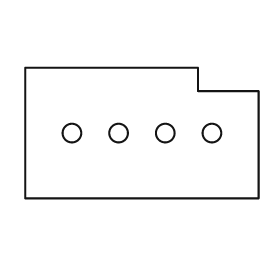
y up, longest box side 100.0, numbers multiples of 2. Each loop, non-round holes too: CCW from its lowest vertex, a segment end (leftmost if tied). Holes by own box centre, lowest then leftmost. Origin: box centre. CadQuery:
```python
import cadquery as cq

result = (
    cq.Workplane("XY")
    .moveTo(-50.0, -28.0)
    .lineTo(50.0, -28.0)
    .lineTo(50.0, 18.0)
    .lineTo(24.0, 18.0)
    .lineTo(24.0, 28.0)
    .lineTo(-50.0, 28.0)
    .close()
    .moveTo(-30.0, 0.0)
    .circle(4.0)
    .moveTo(-10.0, 0.0)
    .circle(4.0)
    .moveTo(10.0, 0.0)
    .circle(4.0)
    .moveTo(30.0, 0.0)
    .circle(4.0)
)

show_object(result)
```